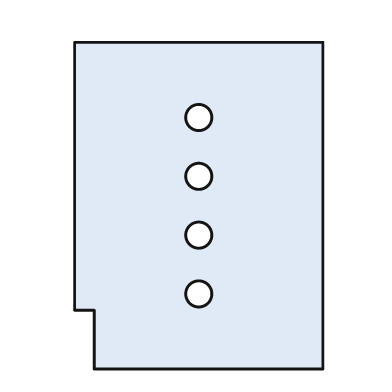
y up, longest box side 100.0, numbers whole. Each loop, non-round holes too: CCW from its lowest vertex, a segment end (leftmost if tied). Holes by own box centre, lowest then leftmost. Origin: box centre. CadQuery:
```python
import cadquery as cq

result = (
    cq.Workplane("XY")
    .moveTo(-32.0, -50.0)
    .lineTo(38.0, -50.0)
    .lineTo(38.0, 50.0)
    .lineTo(-38.0, 50.0)
    .lineTo(-38.0, -32.0)
    .lineTo(-32.0, -32.0)
    .close()
    .moveTo(0.0, -27.0)
    .circle(4.0)
    .moveTo(0.0, -9.0)
    .circle(4.0)
    .moveTo(0.0, 9.0)
    .circle(4.0)
    .moveTo(0.0, 27.0)
    .circle(4.0)
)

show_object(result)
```